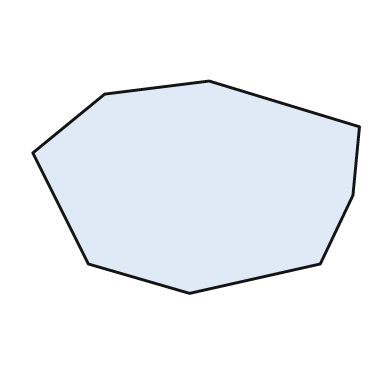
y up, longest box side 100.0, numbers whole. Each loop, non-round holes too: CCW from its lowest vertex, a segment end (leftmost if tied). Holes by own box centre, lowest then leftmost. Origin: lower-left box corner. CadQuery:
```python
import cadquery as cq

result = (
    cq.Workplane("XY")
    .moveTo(48.0, 0.0)
    .lineTo(88.0, 9.0)
    .lineTo(98.0, 30.0)
    .lineTo(100.0, 51.0)
    .lineTo(54.0, 65.0)
    .lineTo(22.0, 61.0)
    .lineTo(0.0, 43.0)
    .lineTo(17.0, 9.0)
    .close()
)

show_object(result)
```